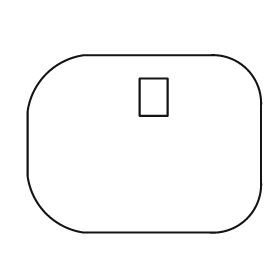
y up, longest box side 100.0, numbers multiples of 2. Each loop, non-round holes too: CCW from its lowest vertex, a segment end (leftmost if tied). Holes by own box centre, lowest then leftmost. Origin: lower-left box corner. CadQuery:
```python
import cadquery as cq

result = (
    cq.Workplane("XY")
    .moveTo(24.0, 0.0)
    .lineTo(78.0, 0.0)
    .threePointArc((94.0, 6.0), (100.0, 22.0))
    .lineTo(100.0, 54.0)
    .threePointArc((94.0, 70.0), (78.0, 76.0))
    .lineTo(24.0, 76.0)
    .threePointArc((8.0, 68.0), (0.0, 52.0))
    .lineTo(0.0, 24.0)
    .threePointArc((8.0, 8.0), (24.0, 0.0))
    .close()
    .moveTo(48.0, 50.0)
    .lineTo(60.0, 50.0)
    .lineTo(60.0, 66.0)
    .lineTo(48.0, 66.0)
    .close()
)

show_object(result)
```